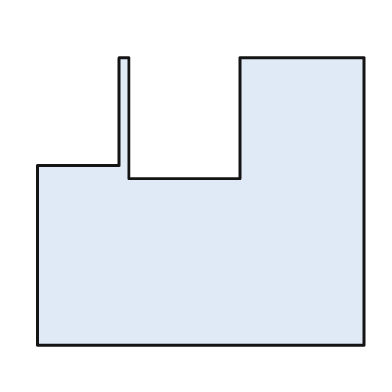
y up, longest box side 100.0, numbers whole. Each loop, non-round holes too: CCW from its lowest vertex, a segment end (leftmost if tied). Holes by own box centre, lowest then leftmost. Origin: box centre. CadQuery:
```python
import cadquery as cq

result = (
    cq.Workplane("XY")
    .moveTo(-50.0, -44.0)
    .lineTo(50.0, -44.0)
    .lineTo(50.0, 44.0)
    .lineTo(12.0, 44.0)
    .lineTo(12.0, 7.0)
    .lineTo(-22.0, 7.0)
    .lineTo(-22.0, 44.0)
    .lineTo(-25.0, 44.0)
    .lineTo(-25.0, 11.0)
    .lineTo(-50.0, 11.0)
    .close()
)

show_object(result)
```